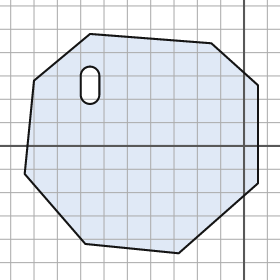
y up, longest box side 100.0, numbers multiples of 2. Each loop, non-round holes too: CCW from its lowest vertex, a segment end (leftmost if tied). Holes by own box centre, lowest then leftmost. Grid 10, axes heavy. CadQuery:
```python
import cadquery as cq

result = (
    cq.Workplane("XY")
    .moveTo(-28.0, -46.0)
    .lineTo(6.0, -16.0)
    .lineTo(6.0, 26.0)
    .lineTo(-14.0, 44.0)
    .lineTo(-66.0, 48.0)
    .lineTo(-90.0, 28.0)
    .lineTo(-94.0, -12.0)
    .lineTo(-68.0, -42.0)
    .close()
    .moveTo(-70.0, 22.0)
    .threePointArc((-66.0, 18.0), (-62.0, 22.0))
    .lineTo(-62.0, 30.0)
    .threePointArc((-66.0, 34.0), (-70.0, 30.0))
    .close()
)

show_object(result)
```